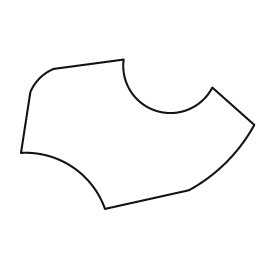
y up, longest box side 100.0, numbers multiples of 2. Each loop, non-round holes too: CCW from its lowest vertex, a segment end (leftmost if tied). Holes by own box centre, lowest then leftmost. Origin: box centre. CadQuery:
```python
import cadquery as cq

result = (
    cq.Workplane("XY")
    .moveTo(-14.0, -32.0)
    .lineTo(22.0, -24.0)
    .threePointArc((38.0, -12.0), (50.0, 4.0))
    .lineTo(32.0, 20.0)
    .threePointArc((8.0, 10.0), (-6.0, 32.0))
    .lineTo(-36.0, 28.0)
    .threePointArc((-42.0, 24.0), (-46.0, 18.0))
    .lineTo(-50.0, -8.0)
    .threePointArc((-28.0, -14.0), (-14.0, -32.0))
    .close()
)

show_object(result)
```